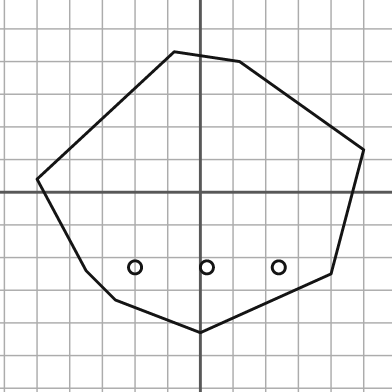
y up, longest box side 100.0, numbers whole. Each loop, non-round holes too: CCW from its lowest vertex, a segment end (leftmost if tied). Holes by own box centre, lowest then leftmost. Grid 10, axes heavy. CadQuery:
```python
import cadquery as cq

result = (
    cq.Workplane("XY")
    .moveTo(0.0, -43.0)
    .lineTo(40.0, -25.0)
    .lineTo(50.0, 13.0)
    .lineTo(12.0, 40.0)
    .lineTo(-8.0, 43.0)
    .lineTo(-50.0, 4.0)
    .lineTo(-35.0, -24.0)
    .lineTo(-26.0, -33.0)
    .close()
    .moveTo(-20.0, -23.0)
    .circle(2.0)
    .moveTo(2.0, -23.0)
    .circle(2.0)
    .moveTo(24.0, -23.0)
    .circle(2.0)
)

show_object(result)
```